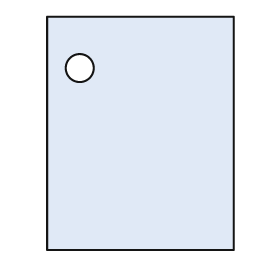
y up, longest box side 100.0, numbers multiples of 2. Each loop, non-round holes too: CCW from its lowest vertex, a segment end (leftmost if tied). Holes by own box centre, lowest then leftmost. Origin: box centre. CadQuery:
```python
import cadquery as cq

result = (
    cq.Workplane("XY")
    .moveTo(-40.0, -50.0)
    .lineTo(40.0, -50.0)
    .lineTo(40.0, 50.0)
    .lineTo(-40.0, 50.0)
    .close()
    .moveTo(-26.0, 28.0)
    .circle(6.0)
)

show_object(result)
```